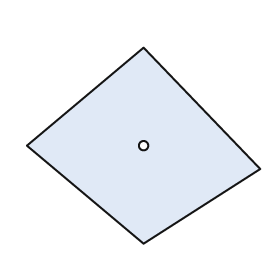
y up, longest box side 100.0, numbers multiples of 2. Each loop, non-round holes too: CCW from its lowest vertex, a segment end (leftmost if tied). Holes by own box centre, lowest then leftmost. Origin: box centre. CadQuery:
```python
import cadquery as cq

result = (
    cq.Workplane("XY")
    .moveTo(0.0, -42.0)
    .lineTo(50.0, -10.0)
    .lineTo(0.0, 42.0)
    .lineTo(-50.0, 0.0)
    .close()
    .moveTo(0.0, 0.0)
    .circle(2.0)
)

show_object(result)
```